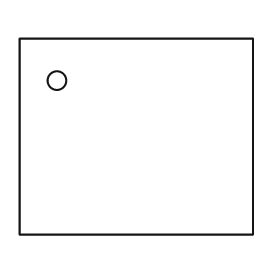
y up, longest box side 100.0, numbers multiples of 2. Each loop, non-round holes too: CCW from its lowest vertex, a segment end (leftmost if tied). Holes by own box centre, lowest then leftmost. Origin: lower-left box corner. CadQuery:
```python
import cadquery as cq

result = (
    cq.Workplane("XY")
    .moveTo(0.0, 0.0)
    .lineTo(100.0, 0.0)
    .lineTo(100.0, 84.0)
    .lineTo(0.0, 84.0)
    .close()
    .moveTo(16.0, 66.0)
    .circle(4.0)
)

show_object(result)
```